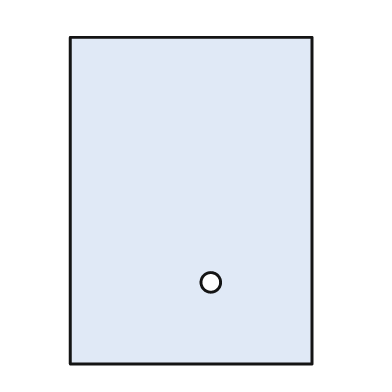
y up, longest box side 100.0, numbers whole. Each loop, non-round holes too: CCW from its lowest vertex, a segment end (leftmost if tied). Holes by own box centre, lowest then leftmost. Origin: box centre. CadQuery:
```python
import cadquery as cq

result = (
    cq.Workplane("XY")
    .moveTo(-37.0, -50.0)
    .lineTo(37.0, -50.0)
    .lineTo(37.0, 50.0)
    .lineTo(-37.0, 50.0)
    .close()
    .moveTo(6.0, -25.0)
    .circle(3.0)
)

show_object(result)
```